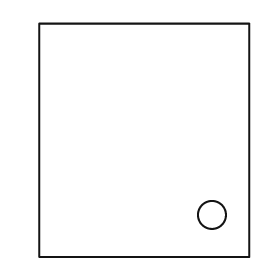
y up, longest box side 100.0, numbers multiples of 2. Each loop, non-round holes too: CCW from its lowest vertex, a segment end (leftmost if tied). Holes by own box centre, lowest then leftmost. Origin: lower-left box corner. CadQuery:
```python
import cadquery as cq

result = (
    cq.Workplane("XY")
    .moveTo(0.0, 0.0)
    .lineTo(90.0, 0.0)
    .lineTo(90.0, 100.0)
    .lineTo(0.0, 100.0)
    .close()
    .moveTo(74.0, 18.0)
    .circle(6.0)
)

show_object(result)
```